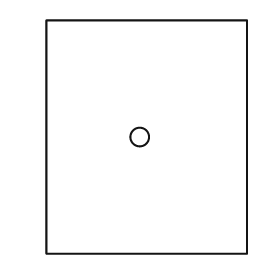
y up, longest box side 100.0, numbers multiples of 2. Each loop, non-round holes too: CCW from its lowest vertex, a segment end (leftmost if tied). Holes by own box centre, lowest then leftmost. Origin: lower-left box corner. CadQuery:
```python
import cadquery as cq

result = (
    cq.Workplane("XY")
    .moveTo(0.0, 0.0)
    .lineTo(86.0, 0.0)
    .lineTo(86.0, 100.0)
    .lineTo(0.0, 100.0)
    .close()
    .moveTo(40.0, 50.0)
    .circle(4.0)
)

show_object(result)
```